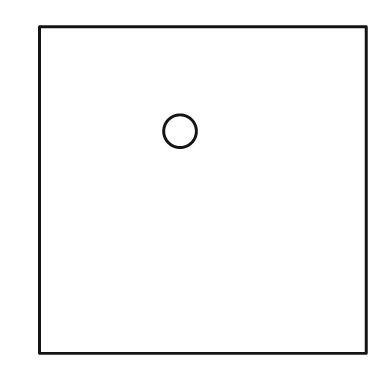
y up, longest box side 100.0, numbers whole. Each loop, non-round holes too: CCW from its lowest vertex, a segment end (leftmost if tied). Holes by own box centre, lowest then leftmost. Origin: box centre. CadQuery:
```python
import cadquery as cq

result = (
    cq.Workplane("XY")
    .moveTo(-50.0, -50.0)
    .lineTo(50.0, -50.0)
    .lineTo(50.0, 50.0)
    .lineTo(-50.0, 50.0)
    .close()
    .moveTo(-7.0, 18.0)
    .circle(5.0)
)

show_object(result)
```